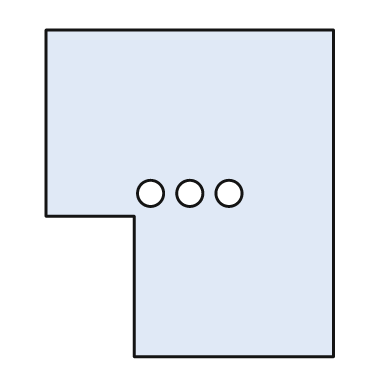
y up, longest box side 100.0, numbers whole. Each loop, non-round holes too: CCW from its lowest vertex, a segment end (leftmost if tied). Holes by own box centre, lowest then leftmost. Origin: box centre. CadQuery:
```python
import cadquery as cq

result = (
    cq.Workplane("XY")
    .moveTo(-17.0, -50.0)
    .lineTo(44.0, -50.0)
    .lineTo(44.0, 50.0)
    .lineTo(-44.0, 50.0)
    .lineTo(-44.0, -7.0)
    .lineTo(-17.0, -7.0)
    .close()
    .moveTo(-12.0, 0.0)
    .circle(4.0)
    .moveTo(0.0, 0.0)
    .circle(4.0)
    .moveTo(12.0, 0.0)
    .circle(4.0)
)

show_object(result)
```